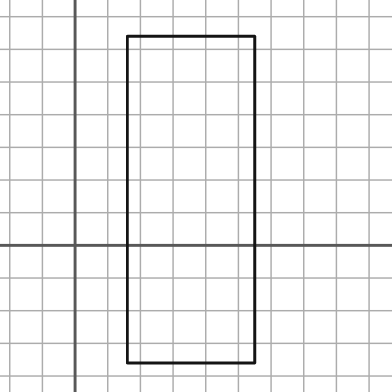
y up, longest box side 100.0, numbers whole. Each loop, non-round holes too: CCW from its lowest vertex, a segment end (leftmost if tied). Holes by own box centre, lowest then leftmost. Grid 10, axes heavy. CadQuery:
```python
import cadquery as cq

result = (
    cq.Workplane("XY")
    .moveTo(16.0, -36.0)
    .lineTo(55.0, -36.0)
    .lineTo(55.0, 64.0)
    .lineTo(16.0, 64.0)
    .close()
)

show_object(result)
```